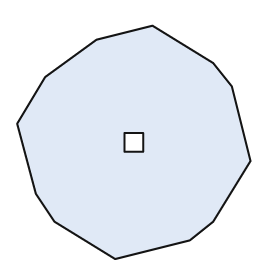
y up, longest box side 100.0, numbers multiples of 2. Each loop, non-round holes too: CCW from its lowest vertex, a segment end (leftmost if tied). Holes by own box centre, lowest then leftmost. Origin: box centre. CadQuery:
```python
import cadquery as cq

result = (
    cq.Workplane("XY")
    .moveTo(-8.0, -50.0)
    .lineTo(24.0, -42.0)
    .lineTo(34.0, -34.0)
    .lineTo(50.0, -8.0)
    .lineTo(42.0, 24.0)
    .lineTo(34.0, 34.0)
    .lineTo(8.0, 50.0)
    .lineTo(-16.0, 44.0)
    .lineTo(-38.0, 28.0)
    .lineTo(-50.0, 8.0)
    .lineTo(-42.0, -22.0)
    .lineTo(-34.0, -34.0)
    .close()
    .moveTo(-4.0, -4.0)
    .lineTo(4.0, -4.0)
    .lineTo(4.0, 4.0)
    .lineTo(-4.0, 4.0)
    .close()
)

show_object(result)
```